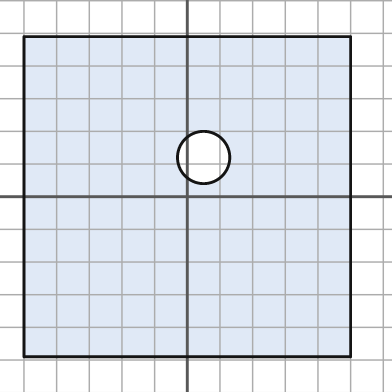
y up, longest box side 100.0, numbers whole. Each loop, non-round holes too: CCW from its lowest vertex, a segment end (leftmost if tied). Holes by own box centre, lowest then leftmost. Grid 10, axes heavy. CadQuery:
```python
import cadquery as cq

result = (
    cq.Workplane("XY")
    .moveTo(-50.0, -49.0)
    .lineTo(50.0, -49.0)
    .lineTo(50.0, 49.0)
    .lineTo(-50.0, 49.0)
    .close()
    .moveTo(5.0, 12.0)
    .circle(8.0)
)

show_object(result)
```